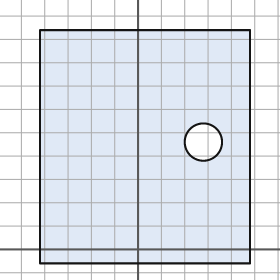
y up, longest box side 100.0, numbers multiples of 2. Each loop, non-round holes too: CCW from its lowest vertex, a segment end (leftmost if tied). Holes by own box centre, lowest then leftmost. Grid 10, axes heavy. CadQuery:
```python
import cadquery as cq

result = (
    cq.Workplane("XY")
    .moveTo(-42.0, -6.0)
    .lineTo(48.0, -6.0)
    .lineTo(48.0, 94.0)
    .lineTo(-42.0, 94.0)
    .close()
    .moveTo(28.0, 46.0)
    .circle(8.0)
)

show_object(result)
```